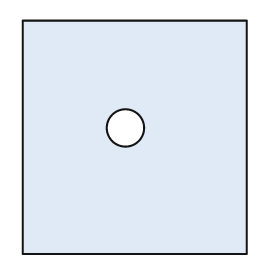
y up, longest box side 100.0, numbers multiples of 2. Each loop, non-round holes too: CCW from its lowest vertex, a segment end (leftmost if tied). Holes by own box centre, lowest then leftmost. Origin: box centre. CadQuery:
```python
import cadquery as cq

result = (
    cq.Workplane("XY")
    .moveTo(-48.0, -50.0)
    .lineTo(48.0, -50.0)
    .lineTo(48.0, 50.0)
    .lineTo(-48.0, 50.0)
    .close()
    .moveTo(-4.0, 4.0)
    .circle(8.0)
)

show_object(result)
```